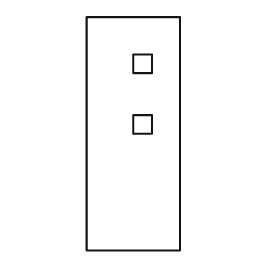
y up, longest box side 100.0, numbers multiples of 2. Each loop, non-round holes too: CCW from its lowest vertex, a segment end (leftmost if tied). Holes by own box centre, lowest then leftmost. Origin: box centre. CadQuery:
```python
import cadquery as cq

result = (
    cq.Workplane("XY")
    .moveTo(-20.0, -50.0)
    .lineTo(20.0, -50.0)
    .lineTo(20.0, 50.0)
    .lineTo(-20.0, 50.0)
    .close()
    .moveTo(0.0, 0.0)
    .lineTo(8.0, 0.0)
    .lineTo(8.0, 8.0)
    .lineTo(0.0, 8.0)
    .close()
    .moveTo(0.0, 26.0)
    .lineTo(8.0, 26.0)
    .lineTo(8.0, 34.0)
    .lineTo(0.0, 34.0)
    .close()
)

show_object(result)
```